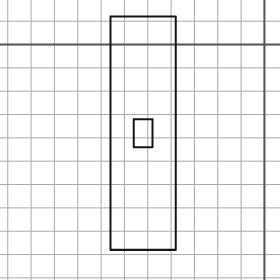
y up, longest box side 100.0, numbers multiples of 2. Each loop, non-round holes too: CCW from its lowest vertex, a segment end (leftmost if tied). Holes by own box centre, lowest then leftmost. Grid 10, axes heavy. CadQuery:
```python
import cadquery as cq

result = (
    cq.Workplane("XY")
    .moveTo(-66.0, -88.0)
    .lineTo(-38.0, -88.0)
    .lineTo(-38.0, 12.0)
    .lineTo(-66.0, 12.0)
    .close()
    .moveTo(-56.0, -44.0)
    .lineTo(-48.0, -44.0)
    .lineTo(-48.0, -32.0)
    .lineTo(-56.0, -32.0)
    .close()
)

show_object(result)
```